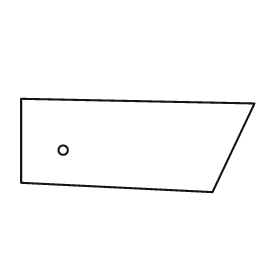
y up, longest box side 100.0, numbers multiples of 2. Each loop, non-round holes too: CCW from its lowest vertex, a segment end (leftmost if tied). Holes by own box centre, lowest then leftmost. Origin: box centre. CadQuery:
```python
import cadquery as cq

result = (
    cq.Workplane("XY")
    .moveTo(32.0, -20.0)
    .lineTo(50.0, 18.0)
    .lineTo(-50.0, 20.0)
    .lineTo(-50.0, -16.0)
    .close()
    .moveTo(-32.0, -2.0)
    .circle(2.0)
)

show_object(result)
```